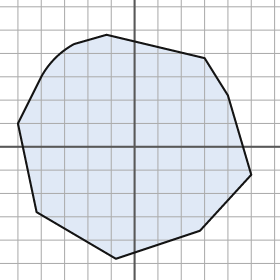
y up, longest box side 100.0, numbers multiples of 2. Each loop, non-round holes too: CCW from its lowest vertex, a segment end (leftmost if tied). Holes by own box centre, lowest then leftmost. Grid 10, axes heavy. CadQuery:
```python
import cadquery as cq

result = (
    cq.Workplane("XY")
    .moveTo(-8.0, -48.0)
    .lineTo(28.0, -36.0)
    .lineTo(50.0, -12.0)
    .lineTo(40.0, 22.0)
    .lineTo(30.0, 38.0)
    .lineTo(-12.0, 48.0)
    .lineTo(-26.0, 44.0)
    .threePointArc((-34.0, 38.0), (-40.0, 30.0))
    .lineTo(-50.0, 10.0)
    .lineTo(-42.0, -28.0)
    .close()
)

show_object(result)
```